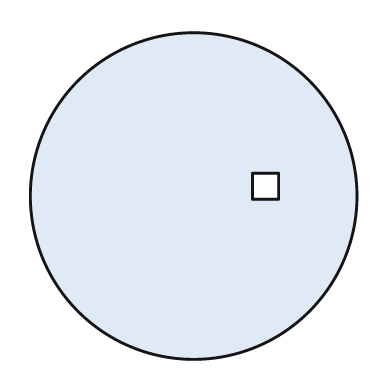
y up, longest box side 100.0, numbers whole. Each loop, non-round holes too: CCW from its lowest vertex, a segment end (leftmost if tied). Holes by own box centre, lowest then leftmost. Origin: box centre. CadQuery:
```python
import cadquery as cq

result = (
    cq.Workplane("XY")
    .moveTo(0.0, 0.0)
    .circle(50.0)
    .moveTo(18.0, -1.0)
    .lineTo(26.0, -1.0)
    .lineTo(26.0, 7.0)
    .lineTo(18.0, 7.0)
    .close()
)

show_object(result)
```